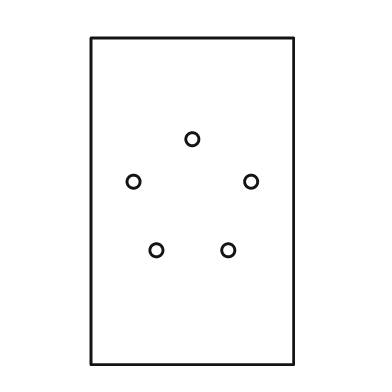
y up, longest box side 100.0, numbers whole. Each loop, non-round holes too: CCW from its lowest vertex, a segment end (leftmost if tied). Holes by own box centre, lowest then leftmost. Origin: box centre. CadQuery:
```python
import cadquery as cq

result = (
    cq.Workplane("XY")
    .moveTo(-31.0, -50.0)
    .lineTo(31.0, -50.0)
    .lineTo(31.0, 50.0)
    .lineTo(-31.0, 50.0)
    .close()
    .moveTo(-11.0, -15.0)
    .circle(2.0)
    .moveTo(11.0, -15.0)
    .circle(2.0)
    .moveTo(-18.0, 6.0)
    .circle(2.0)
    .moveTo(18.0, 6.0)
    .circle(2.0)
    .moveTo(0.0, 19.0)
    .circle(2.0)
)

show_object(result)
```